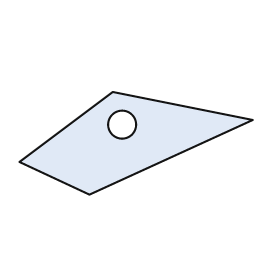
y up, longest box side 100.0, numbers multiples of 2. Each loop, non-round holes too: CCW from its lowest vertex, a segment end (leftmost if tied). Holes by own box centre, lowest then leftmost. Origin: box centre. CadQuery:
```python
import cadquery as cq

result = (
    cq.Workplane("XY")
    .moveTo(-20.0, -22.0)
    .lineTo(50.0, 10.0)
    .lineTo(-10.0, 22.0)
    .lineTo(-50.0, -8.0)
    .close()
    .moveTo(-6.0, 8.0)
    .circle(6.0)
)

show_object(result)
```